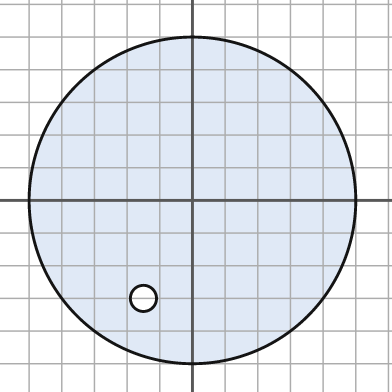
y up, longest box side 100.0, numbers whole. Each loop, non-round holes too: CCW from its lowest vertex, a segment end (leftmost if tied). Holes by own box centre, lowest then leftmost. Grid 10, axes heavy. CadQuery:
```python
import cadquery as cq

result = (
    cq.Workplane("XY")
    .moveTo(0.0, 0.0)
    .circle(50.0)
    .moveTo(-15.0, -30.0)
    .circle(4.0)
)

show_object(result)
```